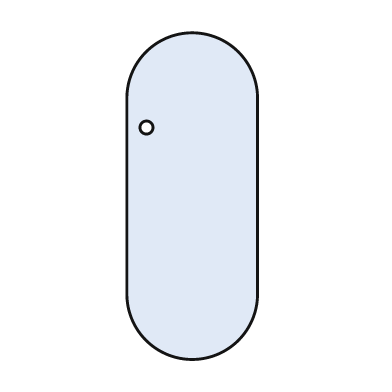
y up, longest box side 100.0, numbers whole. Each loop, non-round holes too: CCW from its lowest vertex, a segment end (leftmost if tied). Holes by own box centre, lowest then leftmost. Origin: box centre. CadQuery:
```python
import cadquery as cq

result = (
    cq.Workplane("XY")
    .moveTo(-20.0, -30.0)
    .threePointArc((0.0, -50.0), (20.0, -30.0))
    .lineTo(20.0, 30.0)
    .threePointArc((0.0, 50.0), (-20.0, 30.0))
    .close()
    .moveTo(-14.0, 21.0)
    .circle(2.0)
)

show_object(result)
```